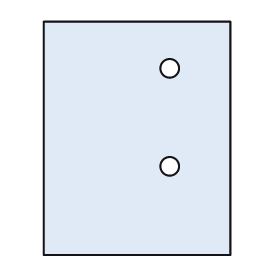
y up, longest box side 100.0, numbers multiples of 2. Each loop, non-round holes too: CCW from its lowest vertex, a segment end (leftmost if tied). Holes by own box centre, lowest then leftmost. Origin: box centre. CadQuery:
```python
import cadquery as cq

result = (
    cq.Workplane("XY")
    .moveTo(-40.0, -50.0)
    .lineTo(40.0, -50.0)
    .lineTo(40.0, 50.0)
    .lineTo(-40.0, 50.0)
    .close()
    .moveTo(14.0, -12.0)
    .circle(4.0)
    .moveTo(14.0, 30.0)
    .circle(4.0)
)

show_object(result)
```